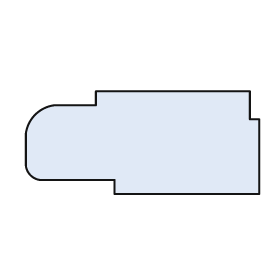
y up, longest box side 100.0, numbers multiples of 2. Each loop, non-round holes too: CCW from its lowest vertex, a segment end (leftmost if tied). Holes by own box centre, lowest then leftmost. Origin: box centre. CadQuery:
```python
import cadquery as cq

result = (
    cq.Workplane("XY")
    .moveTo(-12.0, -22.0)
    .lineTo(50.0, -22.0)
    .lineTo(50.0, 10.0)
    .lineTo(46.0, 10.0)
    .lineTo(46.0, 22.0)
    .lineTo(-20.0, 22.0)
    .lineTo(-20.0, 16.0)
    .lineTo(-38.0, 16.0)
    .threePointArc((-46.0, 12.0), (-50.0, 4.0))
    .lineTo(-50.0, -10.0)
    .threePointArc((-48.0, -14.0), (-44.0, -16.0))
    .lineTo(-12.0, -16.0)
    .close()
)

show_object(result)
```